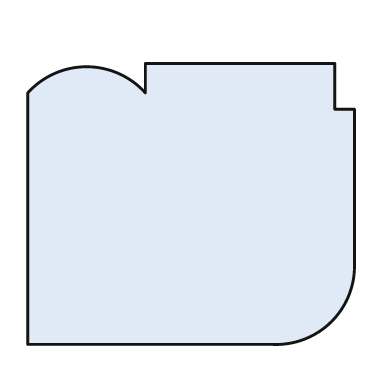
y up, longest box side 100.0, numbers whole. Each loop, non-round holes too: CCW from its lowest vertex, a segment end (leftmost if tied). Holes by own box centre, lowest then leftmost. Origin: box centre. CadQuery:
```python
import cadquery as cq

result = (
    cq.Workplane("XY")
    .moveTo(-50.0, -43.0)
    .lineTo(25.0, -43.0)
    .threePointArc((43.0, -36.0), (50.0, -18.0))
    .lineTo(50.0, 29.0)
    .lineTo(44.0, 29.0)
    .lineTo(44.0, 43.0)
    .lineTo(-14.0, 43.0)
    .lineTo(-14.0, 34.0)
    .threePointArc((-32.0, 42.0), (-50.0, 34.0))
    .close()
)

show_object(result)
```